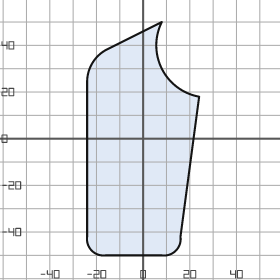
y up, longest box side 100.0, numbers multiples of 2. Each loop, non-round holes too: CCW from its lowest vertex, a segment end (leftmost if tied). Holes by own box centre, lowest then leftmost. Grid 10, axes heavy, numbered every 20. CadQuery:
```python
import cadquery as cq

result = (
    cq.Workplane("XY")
    .moveTo(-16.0, -50.0)
    .lineTo(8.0, -50.0)
    .threePointArc((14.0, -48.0), (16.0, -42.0))
    .lineTo(24.0, 18.0)
    .threePointArc((8.0, 30.0), (8.0, 50.0))
    .lineTo(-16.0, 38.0)
    .threePointArc((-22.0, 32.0), (-24.0, 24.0))
    .lineTo(-24.0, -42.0)
    .threePointArc((-22.0, -48.0), (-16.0, -50.0))
    .close()
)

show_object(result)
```